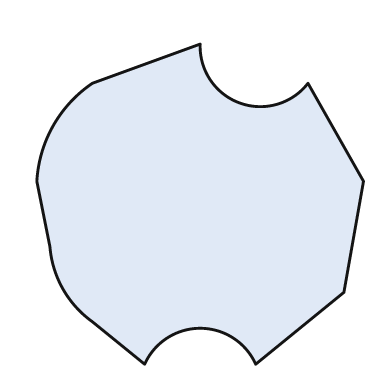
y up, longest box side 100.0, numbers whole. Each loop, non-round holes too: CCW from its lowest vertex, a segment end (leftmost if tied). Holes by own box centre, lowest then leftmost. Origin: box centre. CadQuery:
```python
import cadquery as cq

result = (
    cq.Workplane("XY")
    .moveTo(-17.0, -49.0)
    .threePointArc((0.0, -38.0), (17.0, -49.0))
    .lineTo(44.0, -27.0)
    .lineTo(50.0, 7.0)
    .lineTo(33.0, 37.0)
    .threePointArc((12.0, 31.0), (0.0, 49.0))
    .lineTo(-33.0, 37.0)
    .threePointArc((-45.0, 24.0), (-50.0, 7.0))
    .lineTo(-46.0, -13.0)
    .threePointArc((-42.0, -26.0), (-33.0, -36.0))
    .close()
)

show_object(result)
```